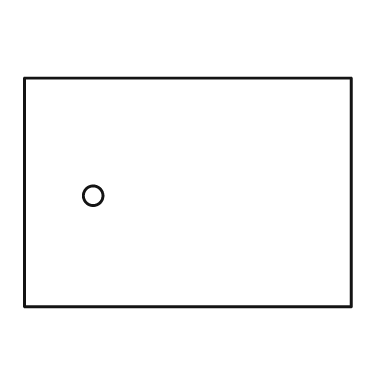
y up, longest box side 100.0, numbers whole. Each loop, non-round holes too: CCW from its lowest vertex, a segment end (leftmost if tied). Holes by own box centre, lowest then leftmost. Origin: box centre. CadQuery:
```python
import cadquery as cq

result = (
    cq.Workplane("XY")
    .moveTo(-50.0, -35.0)
    .lineTo(50.0, -35.0)
    .lineTo(50.0, 35.0)
    .lineTo(-50.0, 35.0)
    .close()
    .moveTo(-29.0, -1.0)
    .circle(3.0)
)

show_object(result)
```